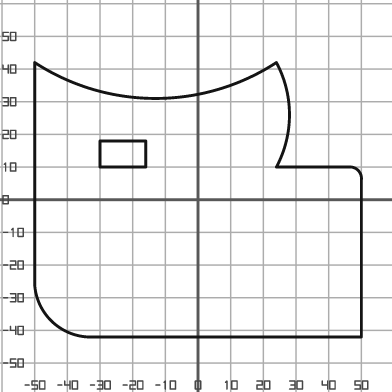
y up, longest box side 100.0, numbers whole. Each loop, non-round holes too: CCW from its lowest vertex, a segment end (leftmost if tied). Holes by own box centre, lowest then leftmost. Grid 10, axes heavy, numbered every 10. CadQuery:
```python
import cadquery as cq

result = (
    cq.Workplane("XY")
    .moveTo(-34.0, -42.0)
    .lineTo(50.0, -42.0)
    .lineTo(50.0, 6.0)
    .threePointArc((49.0, 9.0), (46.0, 10.0))
    .lineTo(24.0, 10.0)
    .threePointArc((28.0, 26.0), (24.0, 42.0))
    .threePointArc((-13.0, 31.0), (-50.0, 42.0))
    .lineTo(-50.0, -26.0)
    .threePointArc((-45.0, -37.0), (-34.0, -42.0))
    .close()
    .moveTo(-30.0, 10.0)
    .lineTo(-16.0, 10.0)
    .lineTo(-16.0, 18.0)
    .lineTo(-30.0, 18.0)
    .close()
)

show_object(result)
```